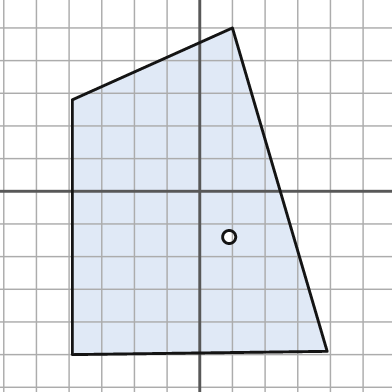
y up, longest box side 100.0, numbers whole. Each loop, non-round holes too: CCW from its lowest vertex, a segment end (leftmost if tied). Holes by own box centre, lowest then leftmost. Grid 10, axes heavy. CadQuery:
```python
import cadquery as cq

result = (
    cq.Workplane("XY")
    .moveTo(-39.0, -50.0)
    .lineTo(39.0, -49.0)
    .lineTo(10.0, 50.0)
    .lineTo(-39.0, 28.0)
    .close()
    .moveTo(9.0, -14.0)
    .circle(2.0)
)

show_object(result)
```